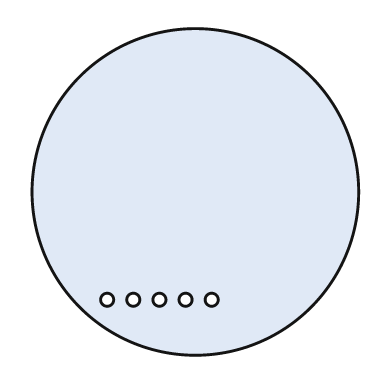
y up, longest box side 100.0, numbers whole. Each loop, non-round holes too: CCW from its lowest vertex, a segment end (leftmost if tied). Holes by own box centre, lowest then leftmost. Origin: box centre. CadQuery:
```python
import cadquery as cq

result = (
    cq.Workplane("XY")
    .moveTo(0.0, 0.0)
    .circle(50.0)
    .moveTo(-27.0, -33.0)
    .circle(2.0)
    .moveTo(-19.0, -33.0)
    .circle(2.0)
    .moveTo(-11.0, -33.0)
    .circle(2.0)
    .moveTo(-3.0, -33.0)
    .circle(2.0)
    .moveTo(5.0, -33.0)
    .circle(2.0)
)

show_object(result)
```